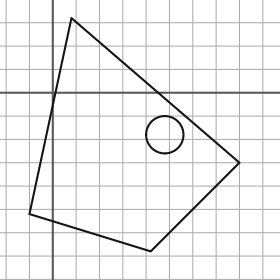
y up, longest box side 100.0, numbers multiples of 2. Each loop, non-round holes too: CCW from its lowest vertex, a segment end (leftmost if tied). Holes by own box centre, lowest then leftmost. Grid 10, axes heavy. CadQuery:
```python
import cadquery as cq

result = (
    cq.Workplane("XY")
    .moveTo(42.0, -68.0)
    .lineTo(80.0, -30.0)
    .lineTo(8.0, 32.0)
    .lineTo(-10.0, -52.0)
    .close()
    .moveTo(48.0, -18.0)
    .circle(8.0)
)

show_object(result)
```